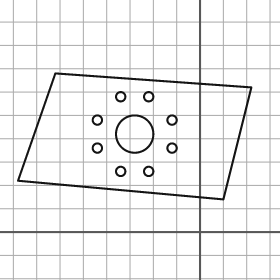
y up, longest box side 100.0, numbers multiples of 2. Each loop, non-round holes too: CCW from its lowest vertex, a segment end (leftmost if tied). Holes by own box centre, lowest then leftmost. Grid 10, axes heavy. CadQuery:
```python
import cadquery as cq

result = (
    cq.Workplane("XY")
    .moveTo(10.0, 14.0)
    .lineTo(22.0, 62.0)
    .lineTo(-62.0, 68.0)
    .lineTo(-78.0, 22.0)
    .close()
    .moveTo(-34.0, 26.0)
    .circle(2.0)
    .moveTo(-22.0, 26.0)
    .circle(2.0)
    .moveTo(-44.0, 36.0)
    .circle(2.0)
    .moveTo(-12.0, 36.0)
    .circle(2.0)
    .moveTo(-28.0, 42.0)
    .circle(8.0)
    .moveTo(-44.0, 48.0)
    .circle(2.0)
    .moveTo(-12.0, 48.0)
    .circle(2.0)
    .moveTo(-34.0, 58.0)
    .circle(2.0)
    .moveTo(-22.0, 58.0)
    .circle(2.0)
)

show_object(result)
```